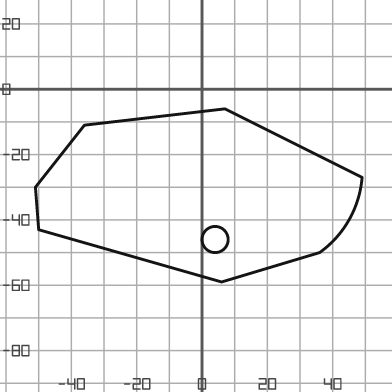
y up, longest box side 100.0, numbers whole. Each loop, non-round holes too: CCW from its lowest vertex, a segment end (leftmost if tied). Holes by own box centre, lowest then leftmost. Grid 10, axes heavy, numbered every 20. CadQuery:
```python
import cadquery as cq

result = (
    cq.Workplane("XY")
    .moveTo(6.0, -59.0)
    .lineTo(36.0, -50.0)
    .threePointArc((45.0, -40.0), (49.0, -27.0))
    .lineTo(7.0, -6.0)
    .lineTo(-36.0, -11.0)
    .lineTo(-51.0, -30.0)
    .lineTo(-50.0, -43.0)
    .close()
    .moveTo(4.0, -46.0)
    .circle(4.0)
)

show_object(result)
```